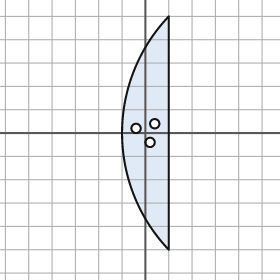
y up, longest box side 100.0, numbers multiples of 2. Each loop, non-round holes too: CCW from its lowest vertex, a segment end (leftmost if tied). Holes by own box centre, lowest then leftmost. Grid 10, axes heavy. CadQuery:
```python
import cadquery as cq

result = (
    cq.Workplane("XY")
    .moveTo(10.0, -50.0)
    .lineTo(10.0, 50.0)
    .threePointArc((-10.0, 0.0), (10.0, -50.0))
    .close()
    .moveTo(2.0, -4.0)
    .circle(2.0)
    .moveTo(-4.0, 2.0)
    .circle(2.0)
    .moveTo(4.0, 4.0)
    .circle(2.0)
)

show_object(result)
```